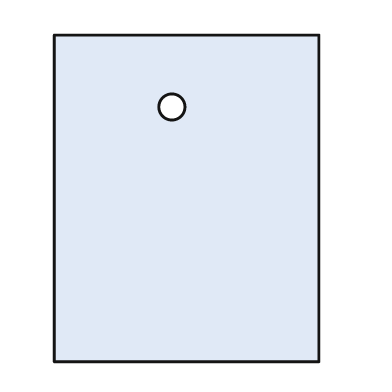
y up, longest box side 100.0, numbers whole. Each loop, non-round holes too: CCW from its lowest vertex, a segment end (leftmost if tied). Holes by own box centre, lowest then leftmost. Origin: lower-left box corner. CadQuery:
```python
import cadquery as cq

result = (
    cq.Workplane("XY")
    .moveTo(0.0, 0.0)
    .lineTo(81.0, 0.0)
    .lineTo(81.0, 100.0)
    .lineTo(0.0, 100.0)
    .close()
    .moveTo(36.0, 78.0)
    .circle(4.0)
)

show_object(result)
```